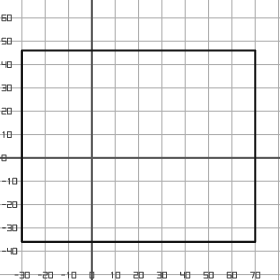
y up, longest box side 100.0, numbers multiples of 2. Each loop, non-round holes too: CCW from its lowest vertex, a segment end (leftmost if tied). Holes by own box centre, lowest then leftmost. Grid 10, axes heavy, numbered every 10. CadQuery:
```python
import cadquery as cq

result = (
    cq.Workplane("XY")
    .moveTo(-30.0, -36.0)
    .lineTo(70.0, -36.0)
    .lineTo(70.0, 46.0)
    .lineTo(-30.0, 46.0)
    .close()
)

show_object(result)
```